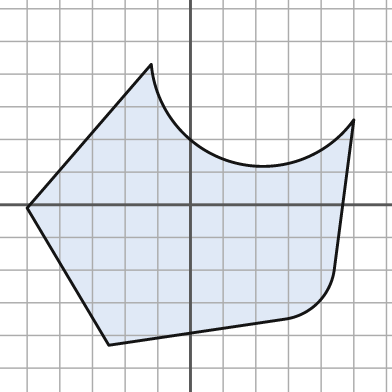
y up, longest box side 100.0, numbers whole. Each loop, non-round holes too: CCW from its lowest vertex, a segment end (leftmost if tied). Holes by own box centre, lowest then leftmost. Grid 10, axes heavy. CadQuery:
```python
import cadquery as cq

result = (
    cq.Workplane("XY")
    .moveTo(-25.0, -43.0)
    .lineTo(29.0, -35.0)
    .threePointArc((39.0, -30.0), (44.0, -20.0))
    .lineTo(50.0, 26.0)
    .threePointArc((13.0, 13.0), (-12.0, 43.0))
    .lineTo(-50.0, -1.0)
    .close()
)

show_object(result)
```